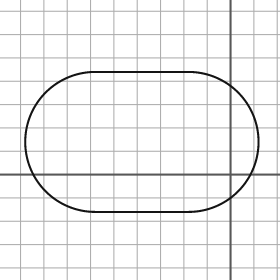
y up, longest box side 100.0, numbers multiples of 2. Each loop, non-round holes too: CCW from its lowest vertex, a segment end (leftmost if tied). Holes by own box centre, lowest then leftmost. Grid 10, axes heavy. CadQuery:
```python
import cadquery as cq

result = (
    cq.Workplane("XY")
    .moveTo(-58.0, -16.0)
    .lineTo(-18.0, -16.0)
    .threePointArc((12.0, 14.0), (-18.0, 44.0))
    .lineTo(-58.0, 44.0)
    .threePointArc((-88.0, 14.0), (-58.0, -16.0))
    .close()
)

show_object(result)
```